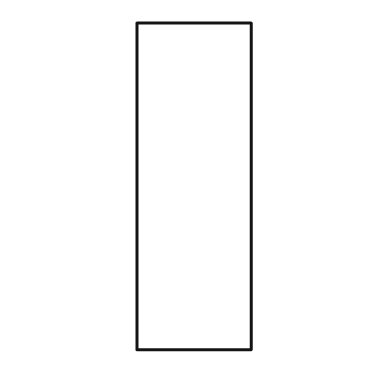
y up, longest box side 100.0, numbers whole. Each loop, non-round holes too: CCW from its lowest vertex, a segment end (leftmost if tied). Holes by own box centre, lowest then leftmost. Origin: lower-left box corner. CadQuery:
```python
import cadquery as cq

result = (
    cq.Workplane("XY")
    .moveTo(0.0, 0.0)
    .lineTo(35.0, 0.0)
    .lineTo(35.0, 100.0)
    .lineTo(0.0, 100.0)
    .close()
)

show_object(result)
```